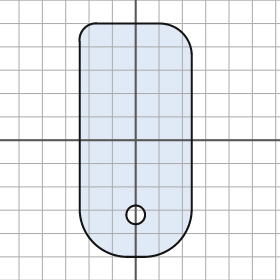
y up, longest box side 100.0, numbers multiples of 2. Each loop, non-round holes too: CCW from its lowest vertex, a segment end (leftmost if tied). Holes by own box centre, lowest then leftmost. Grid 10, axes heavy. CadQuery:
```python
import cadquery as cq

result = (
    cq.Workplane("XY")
    .moveTo(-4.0, -50.0)
    .lineTo(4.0, -50.0)
    .threePointArc((18.0, -44.0), (24.0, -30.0))
    .lineTo(24.0, 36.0)
    .threePointArc((20.0, 46.0), (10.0, 50.0))
    .lineTo(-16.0, 50.0)
    .threePointArc((-22.0, 48.0), (-24.0, 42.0))
    .lineTo(-24.0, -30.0)
    .threePointArc((-18.0, -44.0), (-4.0, -50.0))
    .close()
    .moveTo(0.0, -32.0)
    .circle(4.0)
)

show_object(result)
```